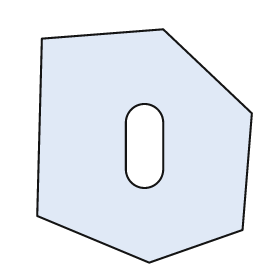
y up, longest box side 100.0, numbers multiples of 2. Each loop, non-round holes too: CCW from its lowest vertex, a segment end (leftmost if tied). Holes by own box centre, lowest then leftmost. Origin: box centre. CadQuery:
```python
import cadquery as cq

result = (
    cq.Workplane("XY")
    .moveTo(2.0, -50.0)
    .lineTo(42.0, -36.0)
    .lineTo(46.0, 14.0)
    .lineTo(8.0, 50.0)
    .lineTo(-44.0, 46.0)
    .lineTo(-46.0, -30.0)
    .close()
    .moveTo(-8.0, -10.0)
    .threePointArc((0.0, -18.0), (8.0, -10.0))
    .lineTo(8.0, 10.0)
    .threePointArc((0.0, 18.0), (-8.0, 10.0))
    .close()
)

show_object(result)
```